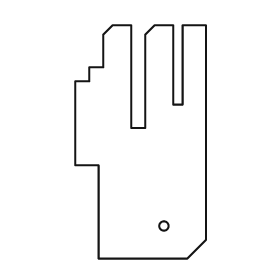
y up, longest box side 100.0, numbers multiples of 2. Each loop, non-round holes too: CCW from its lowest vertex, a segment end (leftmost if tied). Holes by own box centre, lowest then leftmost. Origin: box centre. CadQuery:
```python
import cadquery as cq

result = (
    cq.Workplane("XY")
    .moveTo(-18.0, -50.0)
    .lineTo(20.0, -50.0)
    .lineTo(28.0, -42.0)
    .lineTo(28.0, 50.0)
    .lineTo(18.0, 50.0)
    .lineTo(18.0, 16.0)
    .lineTo(14.0, 16.0)
    .lineTo(14.0, 50.0)
    .lineTo(6.0, 50.0)
    .lineTo(2.0, 46.0)
    .lineTo(2.0, 6.0)
    .lineTo(-4.0, 6.0)
    .lineTo(-4.0, 50.0)
    .lineTo(-12.0, 50.0)
    .lineTo(-16.0, 46.0)
    .lineTo(-16.0, 32.0)
    .lineTo(-22.0, 32.0)
    .lineTo(-22.0, 26.0)
    .lineTo(-28.0, 26.0)
    .lineTo(-28.0, -10.0)
    .lineTo(-18.0, -10.0)
    .close()
    .moveTo(10.0, -36.0)
    .circle(2.0)
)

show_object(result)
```